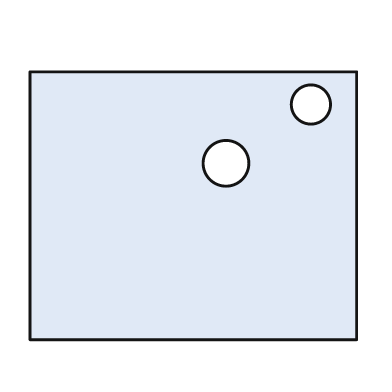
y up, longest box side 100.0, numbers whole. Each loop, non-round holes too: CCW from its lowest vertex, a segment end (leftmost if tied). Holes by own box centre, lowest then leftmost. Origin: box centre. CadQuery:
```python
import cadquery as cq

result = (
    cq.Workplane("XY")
    .moveTo(-50.0, -41.0)
    .lineTo(50.0, -41.0)
    .lineTo(50.0, 41.0)
    .lineTo(-50.0, 41.0)
    .close()
    .moveTo(10.0, 13.0)
    .circle(7.0)
    .moveTo(36.0, 31.0)
    .circle(6.0)
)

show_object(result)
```